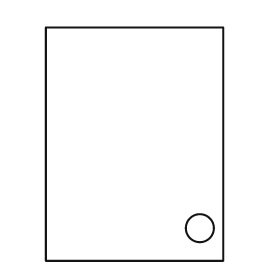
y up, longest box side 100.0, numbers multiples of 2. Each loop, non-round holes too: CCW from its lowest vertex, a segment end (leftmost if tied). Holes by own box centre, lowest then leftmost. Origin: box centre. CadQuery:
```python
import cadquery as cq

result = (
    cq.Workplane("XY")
    .moveTo(-38.0, -50.0)
    .lineTo(38.0, -50.0)
    .lineTo(38.0, 50.0)
    .lineTo(-38.0, 50.0)
    .close()
    .moveTo(28.0, -36.0)
    .circle(6.0)
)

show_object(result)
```